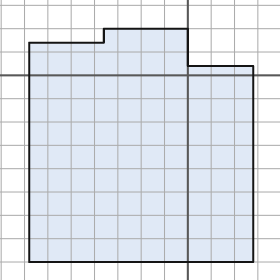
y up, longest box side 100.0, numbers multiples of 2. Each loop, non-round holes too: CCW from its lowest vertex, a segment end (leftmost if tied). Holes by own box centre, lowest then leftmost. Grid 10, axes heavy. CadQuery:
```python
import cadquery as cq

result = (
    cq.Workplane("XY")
    .moveTo(-68.0, -80.0)
    .lineTo(28.0, -80.0)
    .lineTo(28.0, 4.0)
    .lineTo(0.0, 4.0)
    .lineTo(0.0, 20.0)
    .lineTo(-36.0, 20.0)
    .lineTo(-36.0, 14.0)
    .lineTo(-68.0, 14.0)
    .close()
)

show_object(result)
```